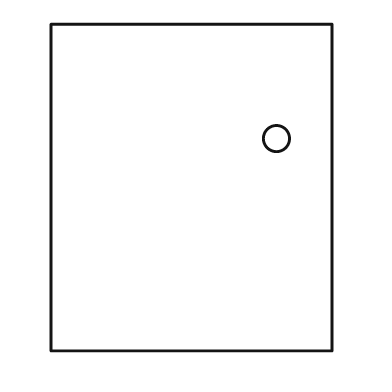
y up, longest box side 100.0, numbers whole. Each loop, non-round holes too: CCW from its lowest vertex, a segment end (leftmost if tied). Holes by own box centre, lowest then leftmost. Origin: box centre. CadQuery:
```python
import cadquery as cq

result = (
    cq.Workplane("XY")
    .moveTo(-43.0, -50.0)
    .lineTo(43.0, -50.0)
    .lineTo(43.0, 50.0)
    .lineTo(-43.0, 50.0)
    .close()
    .moveTo(26.0, 15.0)
    .circle(4.0)
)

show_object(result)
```